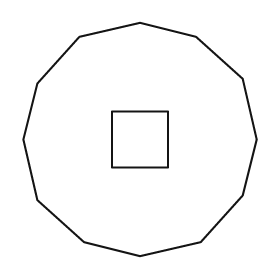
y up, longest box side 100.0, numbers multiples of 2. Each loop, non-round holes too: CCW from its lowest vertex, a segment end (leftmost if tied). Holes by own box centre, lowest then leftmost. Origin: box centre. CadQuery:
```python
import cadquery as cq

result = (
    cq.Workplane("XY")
    .moveTo(0.0, -50.0)
    .lineTo(26.0, -44.0)
    .lineTo(44.0, -24.0)
    .lineTo(50.0, 0.0)
    .lineTo(44.0, 26.0)
    .lineTo(24.0, 44.0)
    .lineTo(0.0, 50.0)
    .lineTo(-26.0, 44.0)
    .lineTo(-44.0, 24.0)
    .lineTo(-50.0, 0.0)
    .lineTo(-44.0, -26.0)
    .lineTo(-24.0, -44.0)
    .close()
    .moveTo(-12.0, -12.0)
    .lineTo(12.0, -12.0)
    .lineTo(12.0, 12.0)
    .lineTo(-12.0, 12.0)
    .close()
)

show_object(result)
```